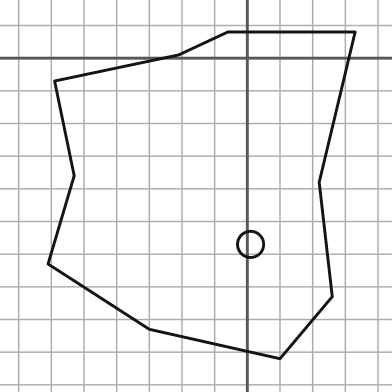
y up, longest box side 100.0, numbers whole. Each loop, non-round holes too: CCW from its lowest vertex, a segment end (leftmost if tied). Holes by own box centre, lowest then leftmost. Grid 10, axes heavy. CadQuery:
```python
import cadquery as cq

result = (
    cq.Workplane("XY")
    .moveTo(10.0, -92.0)
    .lineTo(26.0, -73.0)
    .lineTo(22.0, -38.0)
    .lineTo(33.0, 8.0)
    .lineTo(-6.0, 8.0)
    .lineTo(-21.0, 1.0)
    .lineTo(-59.0, -7.0)
    .lineTo(-53.0, -36.0)
    .lineTo(-61.0, -63.0)
    .lineTo(-30.0, -83.0)
    .close()
    .moveTo(1.0, -57.0)
    .circle(4.0)
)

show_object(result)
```